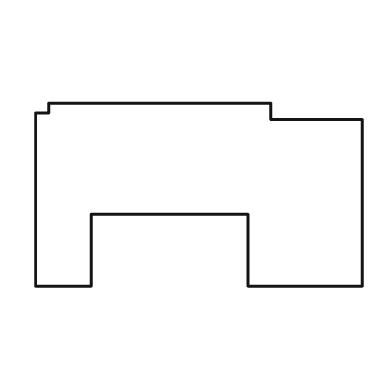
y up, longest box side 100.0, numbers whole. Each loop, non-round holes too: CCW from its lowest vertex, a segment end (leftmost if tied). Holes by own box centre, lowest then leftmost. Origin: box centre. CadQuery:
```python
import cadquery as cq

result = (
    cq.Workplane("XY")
    .moveTo(-50.0, -28.0)
    .lineTo(-33.0, -28.0)
    .lineTo(-33.0, -6.0)
    .lineTo(15.0, -6.0)
    .lineTo(15.0, -28.0)
    .lineTo(50.0, -28.0)
    .lineTo(50.0, 23.0)
    .lineTo(22.0, 23.0)
    .lineTo(22.0, 28.0)
    .lineTo(-46.0, 28.0)
    .lineTo(-46.0, 25.0)
    .lineTo(-50.0, 25.0)
    .close()
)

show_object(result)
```